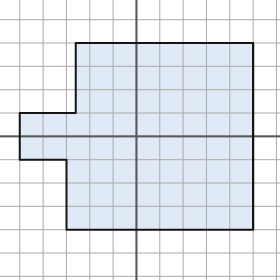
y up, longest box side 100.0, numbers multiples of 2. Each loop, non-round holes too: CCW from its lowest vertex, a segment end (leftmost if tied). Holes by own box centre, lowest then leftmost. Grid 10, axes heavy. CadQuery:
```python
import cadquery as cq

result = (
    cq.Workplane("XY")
    .moveTo(-30.0, -40.0)
    .lineTo(50.0, -40.0)
    .lineTo(50.0, 40.0)
    .lineTo(-26.0, 40.0)
    .lineTo(-26.0, 10.0)
    .lineTo(-50.0, 10.0)
    .lineTo(-50.0, -10.0)
    .lineTo(-30.0, -10.0)
    .close()
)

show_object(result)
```